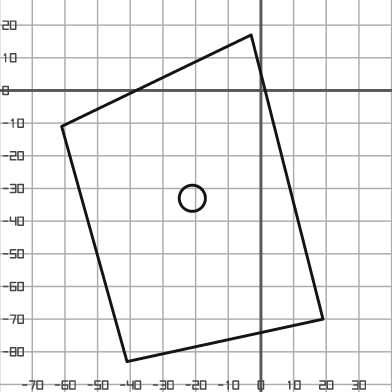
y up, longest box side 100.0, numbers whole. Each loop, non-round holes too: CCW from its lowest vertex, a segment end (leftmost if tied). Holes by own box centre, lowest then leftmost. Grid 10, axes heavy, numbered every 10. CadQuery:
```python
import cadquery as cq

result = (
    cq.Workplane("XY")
    .moveTo(-41.0, -83.0)
    .lineTo(19.0, -70.0)
    .lineTo(-3.0, 17.0)
    .lineTo(-61.0, -11.0)
    .close()
    .moveTo(-21.0, -33.0)
    .circle(4.0)
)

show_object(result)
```